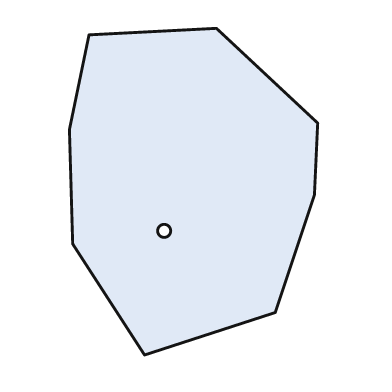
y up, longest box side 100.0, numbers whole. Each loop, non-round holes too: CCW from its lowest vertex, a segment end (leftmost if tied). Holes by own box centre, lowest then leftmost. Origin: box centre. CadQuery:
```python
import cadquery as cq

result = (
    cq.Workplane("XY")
    .moveTo(-15.0, -50.0)
    .lineTo(25.0, -37.0)
    .lineTo(37.0, -1.0)
    .lineTo(38.0, 21.0)
    .lineTo(7.0, 50.0)
    .lineTo(-32.0, 48.0)
    .lineTo(-38.0, 19.0)
    .lineTo(-37.0, -16.0)
    .close()
    .moveTo(-9.0, -12.0)
    .circle(2.0)
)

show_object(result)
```